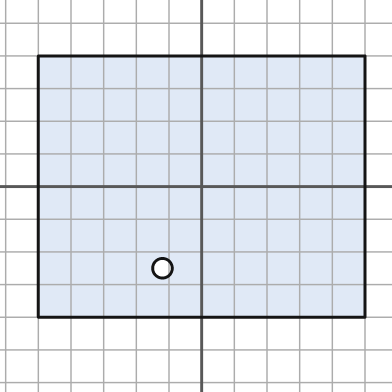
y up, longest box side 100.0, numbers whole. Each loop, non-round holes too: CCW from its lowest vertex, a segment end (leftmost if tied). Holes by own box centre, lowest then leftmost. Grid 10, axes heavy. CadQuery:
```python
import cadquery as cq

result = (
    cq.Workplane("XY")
    .moveTo(-50.0, -40.0)
    .lineTo(50.0, -40.0)
    .lineTo(50.0, 40.0)
    .lineTo(-50.0, 40.0)
    .close()
    .moveTo(-12.0, -25.0)
    .circle(3.0)
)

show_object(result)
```